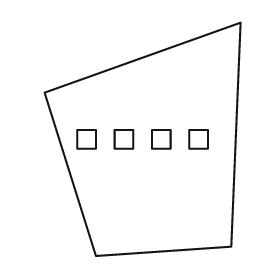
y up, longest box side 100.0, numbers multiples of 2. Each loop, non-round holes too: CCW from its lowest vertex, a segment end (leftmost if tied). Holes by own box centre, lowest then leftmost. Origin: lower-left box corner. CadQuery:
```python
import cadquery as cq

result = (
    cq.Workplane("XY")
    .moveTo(22.0, 0.0)
    .lineTo(80.0, 4.0)
    .lineTo(84.0, 100.0)
    .lineTo(0.0, 70.0)
    .close()
    .moveTo(14.0, 46.0)
    .lineTo(22.0, 46.0)
    .lineTo(22.0, 54.0)
    .lineTo(14.0, 54.0)
    .close()
    .moveTo(30.0, 46.0)
    .lineTo(38.0, 46.0)
    .lineTo(38.0, 54.0)
    .lineTo(30.0, 54.0)
    .close()
    .moveTo(46.0, 46.0)
    .lineTo(54.0, 46.0)
    .lineTo(54.0, 54.0)
    .lineTo(46.0, 54.0)
    .close()
    .moveTo(62.0, 46.0)
    .lineTo(70.0, 46.0)
    .lineTo(70.0, 54.0)
    .lineTo(62.0, 54.0)
    .close()
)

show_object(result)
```